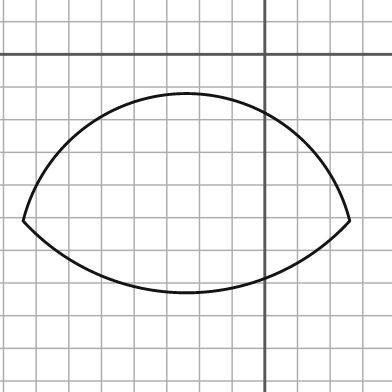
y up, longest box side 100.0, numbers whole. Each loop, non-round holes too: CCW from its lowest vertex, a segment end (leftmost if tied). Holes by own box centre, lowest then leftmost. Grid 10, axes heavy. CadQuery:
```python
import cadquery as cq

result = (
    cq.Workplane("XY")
    .moveTo(-74.0, -51.0)
    .threePointArc((-24.0, -73.0), (26.0, -51.0))
    .threePointArc((-24.0, -12.0), (-74.0, -51.0))
    .close()
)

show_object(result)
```